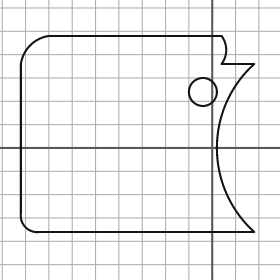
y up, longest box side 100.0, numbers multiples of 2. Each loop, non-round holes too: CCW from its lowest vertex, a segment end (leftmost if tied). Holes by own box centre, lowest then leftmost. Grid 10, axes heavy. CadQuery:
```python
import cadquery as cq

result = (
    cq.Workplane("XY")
    .moveTo(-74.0, -36.0)
    .lineTo(18.0, -36.0)
    .threePointArc((2.0, 0.0), (18.0, 36.0))
    .lineTo(4.0, 36.0)
    .threePointArc((6.0, 42.0), (4.0, 48.0))
    .lineTo(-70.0, 48.0)
    .threePointArc((-78.0, 44.0), (-82.0, 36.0))
    .lineTo(-82.0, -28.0)
    .threePointArc((-80.0, -34.0), (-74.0, -36.0))
    .close()
    .moveTo(-4.0, 24.0)
    .circle(6.0)
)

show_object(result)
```